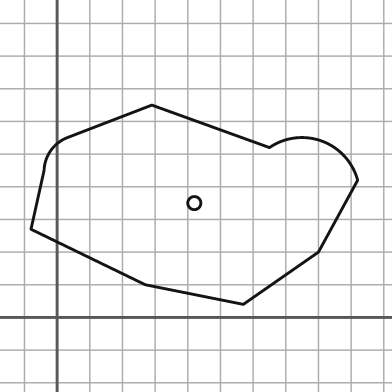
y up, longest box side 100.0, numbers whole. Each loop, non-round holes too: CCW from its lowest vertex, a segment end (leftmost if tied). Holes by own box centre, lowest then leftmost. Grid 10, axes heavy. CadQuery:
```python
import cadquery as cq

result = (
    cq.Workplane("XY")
    .moveTo(57.0, 4.0)
    .lineTo(80.0, 20.0)
    .lineTo(92.0, 42.0)
    .threePointArc((81.0, 54.0), (65.0, 52.0))
    .lineTo(29.0, 65.0)
    .lineTo(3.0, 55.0)
    .threePointArc((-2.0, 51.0), (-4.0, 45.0))
    .lineTo(-8.0, 27.0)
    .lineTo(27.0, 10.0)
    .close()
    .moveTo(42.0, 35.0)
    .circle(2.0)
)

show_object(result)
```